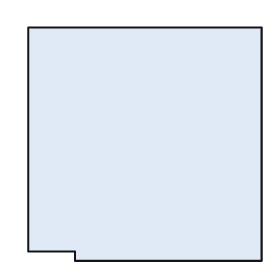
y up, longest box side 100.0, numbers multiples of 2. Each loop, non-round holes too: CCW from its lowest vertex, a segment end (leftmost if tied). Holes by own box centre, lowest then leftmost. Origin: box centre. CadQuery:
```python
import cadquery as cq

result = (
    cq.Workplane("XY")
    .moveTo(-30.0, -50.0)
    .lineTo(50.0, -50.0)
    .lineTo(50.0, 50.0)
    .lineTo(-50.0, 50.0)
    .lineTo(-50.0, -46.0)
    .lineTo(-30.0, -46.0)
    .close()
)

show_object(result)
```